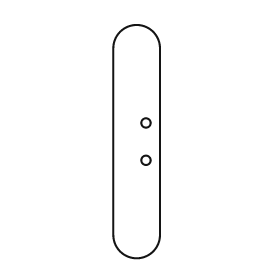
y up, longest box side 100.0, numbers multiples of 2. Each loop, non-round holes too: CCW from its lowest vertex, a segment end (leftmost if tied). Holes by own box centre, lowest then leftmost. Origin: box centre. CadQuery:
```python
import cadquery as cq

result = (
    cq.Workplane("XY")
    .moveTo(-10.0, -40.0)
    .threePointArc((0.0, -50.0), (10.0, -40.0))
    .lineTo(10.0, 40.0)
    .threePointArc((0.0, 50.0), (-10.0, 40.0))
    .close()
    .moveTo(4.0, -8.0)
    .circle(2.0)
    .moveTo(4.0, 8.0)
    .circle(2.0)
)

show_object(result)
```